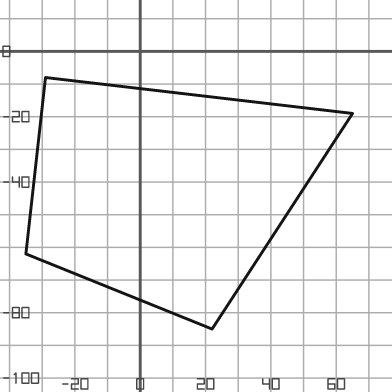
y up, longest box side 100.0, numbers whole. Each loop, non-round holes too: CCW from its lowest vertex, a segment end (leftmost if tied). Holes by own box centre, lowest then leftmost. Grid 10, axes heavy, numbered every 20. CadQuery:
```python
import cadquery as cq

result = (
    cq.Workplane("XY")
    .moveTo(22.0, -85.0)
    .lineTo(65.0, -19.0)
    .lineTo(-29.0, -8.0)
    .lineTo(-35.0, -62.0)
    .close()
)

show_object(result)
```